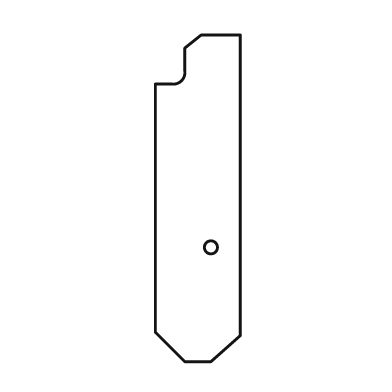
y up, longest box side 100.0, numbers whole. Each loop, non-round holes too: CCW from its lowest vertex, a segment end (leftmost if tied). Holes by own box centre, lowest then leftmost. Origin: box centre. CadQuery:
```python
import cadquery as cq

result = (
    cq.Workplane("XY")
    .moveTo(-4.0, -50.0)
    .lineTo(4.0, -50.0)
    .lineTo(13.0, -42.0)
    .lineTo(13.0, 50.0)
    .lineTo(1.0, 50.0)
    .lineTo(-4.0, 46.0)
    .lineTo(-4.0, 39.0)
    .threePointArc((-5.0, 36.0), (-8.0, 35.0))
    .lineTo(-13.0, 35.0)
    .lineTo(-13.0, -41.0)
    .close()
    .moveTo(4.0, -15.0)
    .circle(2.0)
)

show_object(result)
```